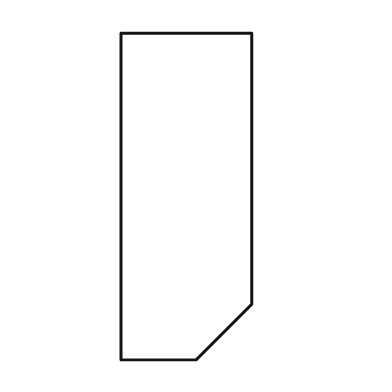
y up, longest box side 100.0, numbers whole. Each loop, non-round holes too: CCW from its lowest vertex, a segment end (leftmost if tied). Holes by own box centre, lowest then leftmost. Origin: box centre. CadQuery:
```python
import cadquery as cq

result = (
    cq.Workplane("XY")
    .moveTo(-20.0, -50.0)
    .lineTo(3.0, -50.0)
    .lineTo(20.0, -33.0)
    .lineTo(20.0, 50.0)
    .lineTo(-20.0, 50.0)
    .close()
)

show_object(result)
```